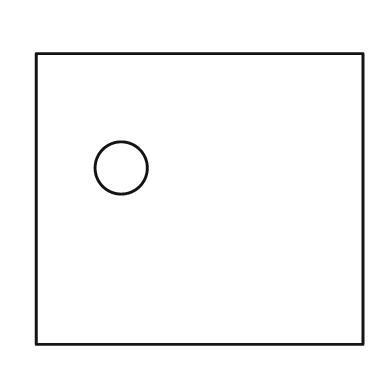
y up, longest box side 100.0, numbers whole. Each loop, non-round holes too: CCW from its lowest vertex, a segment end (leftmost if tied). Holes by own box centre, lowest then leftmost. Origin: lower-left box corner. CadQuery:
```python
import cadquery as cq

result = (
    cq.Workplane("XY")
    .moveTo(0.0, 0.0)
    .lineTo(100.0, 0.0)
    .lineTo(100.0, 89.0)
    .lineTo(0.0, 89.0)
    .close()
    .moveTo(26.0, 54.0)
    .circle(8.0)
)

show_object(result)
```